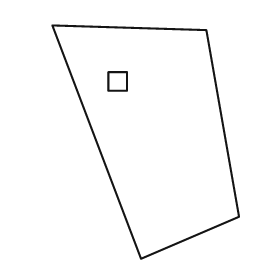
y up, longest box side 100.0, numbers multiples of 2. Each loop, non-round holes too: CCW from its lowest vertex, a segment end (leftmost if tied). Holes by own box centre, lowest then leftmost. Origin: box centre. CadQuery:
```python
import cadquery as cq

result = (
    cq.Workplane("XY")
    .moveTo(-2.0, -50.0)
    .lineTo(40.0, -32.0)
    .lineTo(26.0, 48.0)
    .lineTo(-40.0, 50.0)
    .close()
    .moveTo(-16.0, 22.0)
    .lineTo(-8.0, 22.0)
    .lineTo(-8.0, 30.0)
    .lineTo(-16.0, 30.0)
    .close()
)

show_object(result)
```